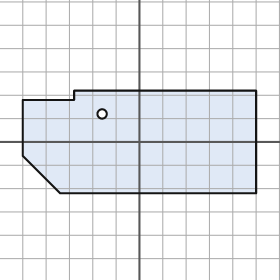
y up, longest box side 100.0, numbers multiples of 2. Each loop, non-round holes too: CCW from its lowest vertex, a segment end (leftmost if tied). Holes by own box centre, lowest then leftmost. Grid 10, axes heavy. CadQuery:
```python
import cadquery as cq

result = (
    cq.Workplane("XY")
    .moveTo(-34.0, -22.0)
    .lineTo(50.0, -22.0)
    .lineTo(50.0, 22.0)
    .lineTo(-28.0, 22.0)
    .lineTo(-28.0, 18.0)
    .lineTo(-50.0, 18.0)
    .lineTo(-50.0, -6.0)
    .close()
    .moveTo(-16.0, 12.0)
    .circle(2.0)
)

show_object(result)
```